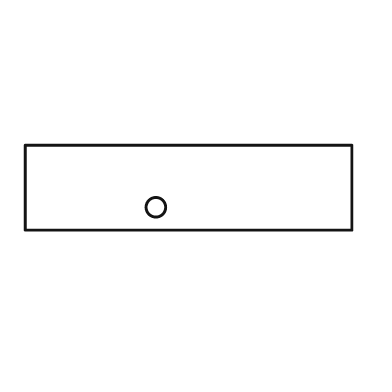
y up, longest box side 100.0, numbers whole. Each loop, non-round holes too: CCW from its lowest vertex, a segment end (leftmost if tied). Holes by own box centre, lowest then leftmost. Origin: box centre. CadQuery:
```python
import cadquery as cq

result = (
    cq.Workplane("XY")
    .moveTo(-50.0, -13.0)
    .lineTo(50.0, -13.0)
    .lineTo(50.0, 13.0)
    .lineTo(-50.0, 13.0)
    .close()
    .moveTo(-10.0, -6.0)
    .circle(3.0)
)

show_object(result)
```